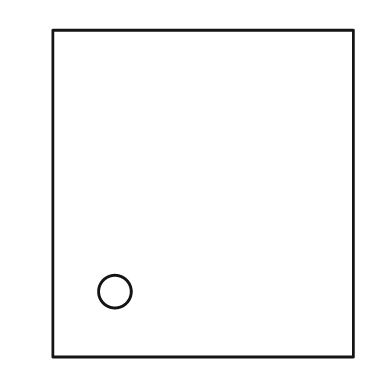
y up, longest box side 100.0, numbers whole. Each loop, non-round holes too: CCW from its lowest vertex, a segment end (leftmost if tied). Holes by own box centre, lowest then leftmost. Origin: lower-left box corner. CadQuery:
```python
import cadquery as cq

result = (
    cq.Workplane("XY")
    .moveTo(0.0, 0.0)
    .lineTo(92.0, 0.0)
    .lineTo(92.0, 100.0)
    .lineTo(0.0, 100.0)
    .close()
    .moveTo(19.0, 20.0)
    .circle(5.0)
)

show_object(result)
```